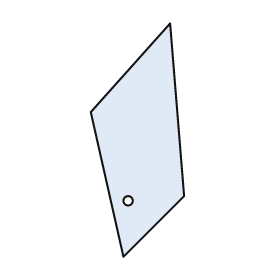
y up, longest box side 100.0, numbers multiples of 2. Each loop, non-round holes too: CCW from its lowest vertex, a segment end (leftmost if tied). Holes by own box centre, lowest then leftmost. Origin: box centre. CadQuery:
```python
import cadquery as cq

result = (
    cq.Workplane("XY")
    .moveTo(-6.0, -50.0)
    .lineTo(20.0, -24.0)
    .lineTo(14.0, 50.0)
    .lineTo(-20.0, 12.0)
    .close()
    .moveTo(-4.0, -26.0)
    .circle(2.0)
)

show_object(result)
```